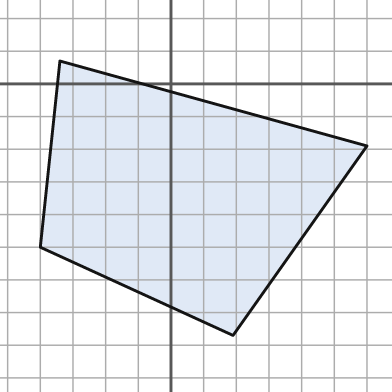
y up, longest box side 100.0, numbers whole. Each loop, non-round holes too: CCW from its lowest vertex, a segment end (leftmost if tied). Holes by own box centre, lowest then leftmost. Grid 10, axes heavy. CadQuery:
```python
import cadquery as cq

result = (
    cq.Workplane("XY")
    .moveTo(19.0, -77.0)
    .lineTo(60.0, -19.0)
    .lineTo(-34.0, 7.0)
    .lineTo(-40.0, -50.0)
    .close()
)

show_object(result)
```